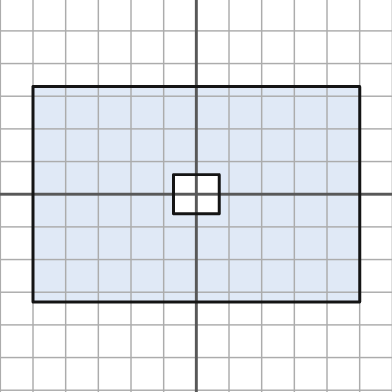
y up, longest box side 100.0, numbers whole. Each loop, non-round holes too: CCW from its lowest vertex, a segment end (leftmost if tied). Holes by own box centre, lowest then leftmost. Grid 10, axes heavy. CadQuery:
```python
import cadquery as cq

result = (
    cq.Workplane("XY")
    .moveTo(-50.0, -33.0)
    .lineTo(50.0, -33.0)
    .lineTo(50.0, 33.0)
    .lineTo(-50.0, 33.0)
    .close()
    .moveTo(-7.0, -6.0)
    .lineTo(7.0, -6.0)
    .lineTo(7.0, 6.0)
    .lineTo(-7.0, 6.0)
    .close()
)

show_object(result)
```